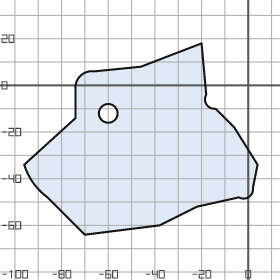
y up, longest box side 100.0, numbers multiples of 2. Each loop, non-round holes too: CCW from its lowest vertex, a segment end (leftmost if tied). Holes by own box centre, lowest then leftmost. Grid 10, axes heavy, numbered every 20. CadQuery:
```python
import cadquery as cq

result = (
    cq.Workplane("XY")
    .moveTo(-70.0, -64.0)
    .lineTo(-38.0, -60.0)
    .lineTo(-22.0, -52.0)
    .lineTo(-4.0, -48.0)
    .threePointArc((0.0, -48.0), (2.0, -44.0))
    .lineTo(4.0, -34.0)
    .lineTo(-6.0, -18.0)
    .lineTo(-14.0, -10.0)
    .threePointArc((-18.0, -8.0), (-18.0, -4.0))
    .lineTo(-20.0, 18.0)
    .lineTo(-46.0, 8.0)
    .lineTo(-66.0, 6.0)
    .threePointArc((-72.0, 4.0), (-74.0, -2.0))
    .lineTo(-74.0, -14.0)
    .lineTo(-96.0, -34.0)
    .threePointArc((-92.0, -42.0), (-86.0, -48.0))
    .close()
    .moveTo(-60.0, -12.0)
    .circle(4.0)
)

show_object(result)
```